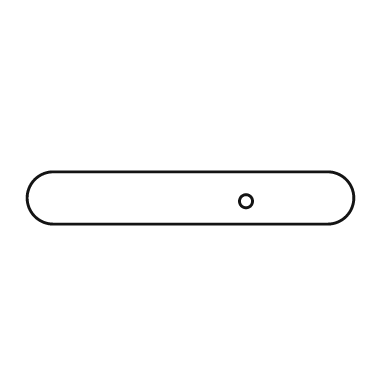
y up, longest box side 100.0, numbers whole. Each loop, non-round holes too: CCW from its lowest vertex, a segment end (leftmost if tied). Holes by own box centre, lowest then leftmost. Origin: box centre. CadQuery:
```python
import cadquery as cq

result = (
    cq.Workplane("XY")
    .moveTo(-42.0, -8.0)
    .lineTo(42.0, -8.0)
    .threePointArc((50.0, 0.0), (42.0, 8.0))
    .lineTo(-42.0, 8.0)
    .threePointArc((-50.0, 0.0), (-42.0, -8.0))
    .close()
    .moveTo(17.0, -1.0)
    .circle(2.0)
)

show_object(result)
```